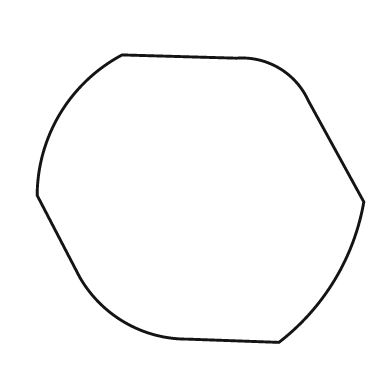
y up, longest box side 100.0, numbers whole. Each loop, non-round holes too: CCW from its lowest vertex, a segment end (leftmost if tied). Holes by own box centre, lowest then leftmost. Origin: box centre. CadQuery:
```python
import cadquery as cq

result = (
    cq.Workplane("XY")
    .moveTo(24.0, -44.0)
    .threePointArc((41.0, -25.0), (50.0, -1.0))
    .lineTo(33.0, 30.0)
    .threePointArc((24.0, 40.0), (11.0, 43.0))
    .lineTo(-24.0, 44.0)
    .threePointArc((-43.0, 26.0), (-50.0, 1.0))
    .lineTo(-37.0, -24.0)
    .threePointArc((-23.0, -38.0), (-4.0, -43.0))
    .close()
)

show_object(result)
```